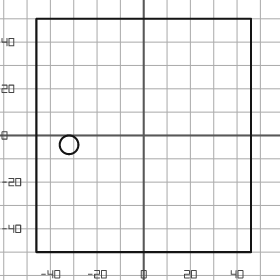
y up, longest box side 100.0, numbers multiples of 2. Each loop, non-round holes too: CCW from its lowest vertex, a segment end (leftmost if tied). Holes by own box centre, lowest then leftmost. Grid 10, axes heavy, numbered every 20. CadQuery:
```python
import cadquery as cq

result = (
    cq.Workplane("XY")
    .moveTo(-46.0, -50.0)
    .lineTo(46.0, -50.0)
    .lineTo(46.0, 50.0)
    .lineTo(-46.0, 50.0)
    .close()
    .moveTo(-32.0, -4.0)
    .circle(4.0)
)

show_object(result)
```